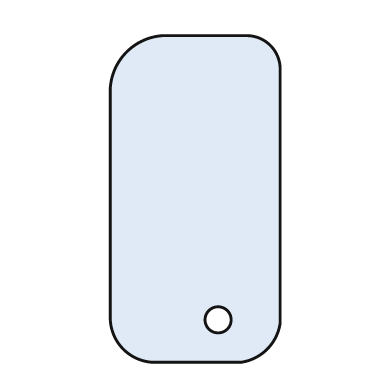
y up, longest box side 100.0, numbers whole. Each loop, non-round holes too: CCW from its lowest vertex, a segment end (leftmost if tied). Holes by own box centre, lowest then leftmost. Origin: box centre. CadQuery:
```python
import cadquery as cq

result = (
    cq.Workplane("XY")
    .moveTo(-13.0, -50.0)
    .lineTo(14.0, -50.0)
    .threePointArc((22.0, -46.0), (26.0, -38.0))
    .lineTo(26.0, 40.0)
    .threePointArc((23.0, 47.0), (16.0, 50.0))
    .lineTo(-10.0, 50.0)
    .threePointArc((-21.0, 45.0), (-26.0, 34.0))
    .lineTo(-26.0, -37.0)
    .threePointArc((-22.0, -46.0), (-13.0, -50.0))
    .close()
    .moveTo(7.0, -37.0)
    .circle(4.0)
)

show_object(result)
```